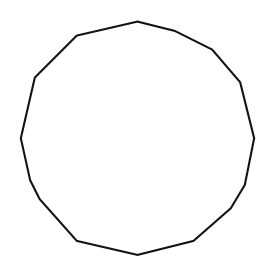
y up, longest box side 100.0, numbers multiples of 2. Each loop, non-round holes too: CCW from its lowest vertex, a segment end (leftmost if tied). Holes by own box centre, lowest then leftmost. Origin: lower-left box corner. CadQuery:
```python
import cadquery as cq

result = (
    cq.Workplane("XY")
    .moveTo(50.0, 0.0)
    .lineTo(74.0, 6.0)
    .lineTo(90.0, 20.0)
    .lineTo(96.0, 30.0)
    .lineTo(100.0, 50.0)
    .lineTo(94.0, 74.0)
    .lineTo(82.0, 88.0)
    .lineTo(66.0, 96.0)
    .lineTo(50.0, 100.0)
    .lineTo(24.0, 94.0)
    .lineTo(6.0, 76.0)
    .lineTo(0.0, 50.0)
    .lineTo(4.0, 32.0)
    .lineTo(8.0, 24.0)
    .lineTo(24.0, 6.0)
    .close()
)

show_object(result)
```